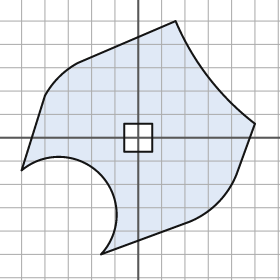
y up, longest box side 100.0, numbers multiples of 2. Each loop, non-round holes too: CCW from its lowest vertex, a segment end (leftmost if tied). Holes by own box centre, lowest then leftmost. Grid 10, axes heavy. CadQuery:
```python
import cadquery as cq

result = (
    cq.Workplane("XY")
    .moveTo(-16.0, -50.0)
    .lineTo(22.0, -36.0)
    .threePointArc((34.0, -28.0), (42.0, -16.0))
    .lineTo(50.0, 6.0)
    .threePointArc((30.0, 26.0), (16.0, 50.0))
    .lineTo(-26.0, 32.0)
    .threePointArc((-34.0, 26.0), (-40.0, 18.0))
    .lineTo(-50.0, -14.0)
    .threePointArc((-16.0, -16.0), (-16.0, -50.0))
    .close()
    .moveTo(-6.0, -6.0)
    .lineTo(6.0, -6.0)
    .lineTo(6.0, 6.0)
    .lineTo(-6.0, 6.0)
    .close()
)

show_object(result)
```